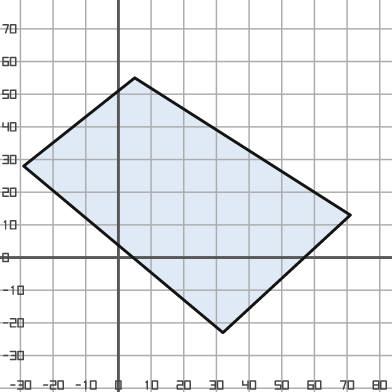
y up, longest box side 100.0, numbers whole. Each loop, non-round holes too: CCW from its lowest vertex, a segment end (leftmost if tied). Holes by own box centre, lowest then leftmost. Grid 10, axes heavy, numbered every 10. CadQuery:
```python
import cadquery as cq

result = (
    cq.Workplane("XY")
    .moveTo(32.0, -23.0)
    .lineTo(71.0, 13.0)
    .lineTo(5.0, 55.0)
    .lineTo(-29.0, 28.0)
    .close()
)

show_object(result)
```